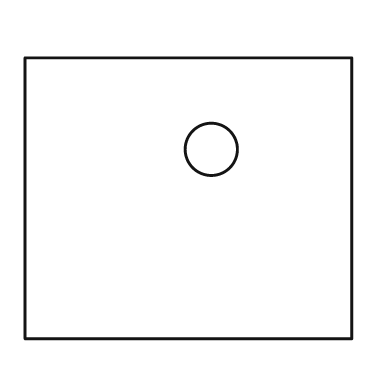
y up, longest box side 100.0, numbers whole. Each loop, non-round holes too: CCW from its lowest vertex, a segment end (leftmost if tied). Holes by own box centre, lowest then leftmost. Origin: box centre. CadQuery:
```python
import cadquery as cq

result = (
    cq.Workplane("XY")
    .moveTo(-50.0, -43.0)
    .lineTo(50.0, -43.0)
    .lineTo(50.0, 43.0)
    .lineTo(-50.0, 43.0)
    .close()
    .moveTo(7.0, 15.0)
    .circle(8.0)
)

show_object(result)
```